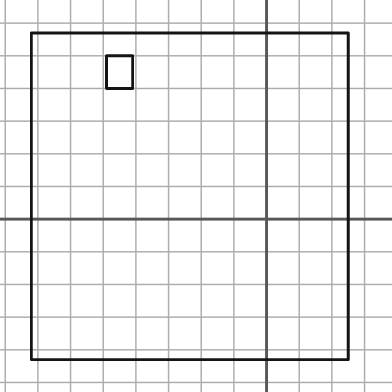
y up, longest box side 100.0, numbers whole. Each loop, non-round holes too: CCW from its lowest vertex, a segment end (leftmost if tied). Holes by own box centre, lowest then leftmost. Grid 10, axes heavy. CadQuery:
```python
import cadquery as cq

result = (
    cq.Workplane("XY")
    .moveTo(-72.0, -43.0)
    .lineTo(25.0, -43.0)
    .lineTo(25.0, 57.0)
    .lineTo(-72.0, 57.0)
    .close()
    .moveTo(-49.0, 40.0)
    .lineTo(-41.0, 40.0)
    .lineTo(-41.0, 50.0)
    .lineTo(-49.0, 50.0)
    .close()
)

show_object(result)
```